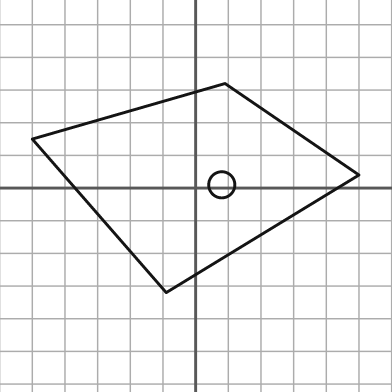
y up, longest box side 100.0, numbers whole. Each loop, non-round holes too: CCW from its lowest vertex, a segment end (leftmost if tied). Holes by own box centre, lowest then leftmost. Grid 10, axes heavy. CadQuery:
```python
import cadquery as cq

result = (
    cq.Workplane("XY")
    .moveTo(-9.0, -32.0)
    .lineTo(50.0, 4.0)
    .lineTo(9.0, 32.0)
    .lineTo(-50.0, 15.0)
    .close()
    .moveTo(8.0, 1.0)
    .circle(4.0)
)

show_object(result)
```